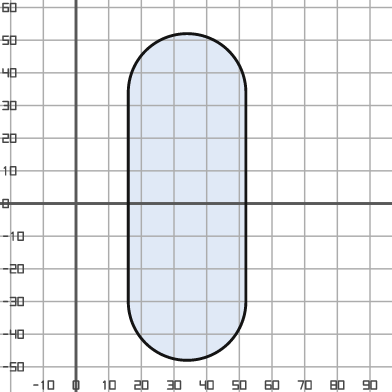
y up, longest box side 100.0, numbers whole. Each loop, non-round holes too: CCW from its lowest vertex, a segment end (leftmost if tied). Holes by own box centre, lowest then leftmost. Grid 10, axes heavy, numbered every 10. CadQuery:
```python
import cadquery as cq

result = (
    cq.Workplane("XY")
    .moveTo(16.0, -30.0)
    .threePointArc((34.0, -48.0), (52.0, -30.0))
    .lineTo(52.0, 34.0)
    .threePointArc((34.0, 52.0), (16.0, 34.0))
    .close()
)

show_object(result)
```